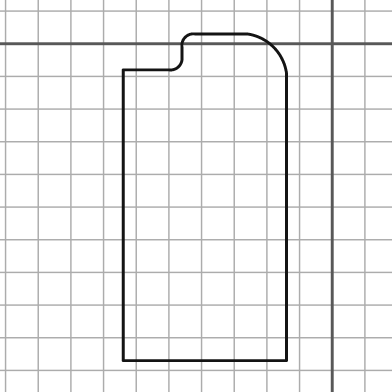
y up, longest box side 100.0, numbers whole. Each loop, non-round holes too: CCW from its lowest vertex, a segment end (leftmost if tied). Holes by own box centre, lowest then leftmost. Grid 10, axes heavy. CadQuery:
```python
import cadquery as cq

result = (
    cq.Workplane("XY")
    .moveTo(-64.0, -97.0)
    .lineTo(-14.0, -97.0)
    .lineTo(-14.0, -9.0)
    .threePointArc((-18.0, -1.0), (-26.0, 3.0))
    .lineTo(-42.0, 3.0)
    .threePointArc((-45.0, 2.0), (-46.0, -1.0))
    .lineTo(-46.0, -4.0)
    .threePointArc((-47.0, -7.0), (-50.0, -8.0))
    .lineTo(-64.0, -8.0)
    .close()
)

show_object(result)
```